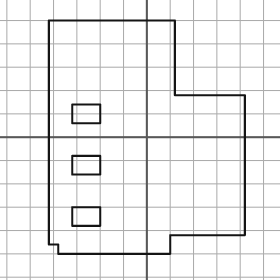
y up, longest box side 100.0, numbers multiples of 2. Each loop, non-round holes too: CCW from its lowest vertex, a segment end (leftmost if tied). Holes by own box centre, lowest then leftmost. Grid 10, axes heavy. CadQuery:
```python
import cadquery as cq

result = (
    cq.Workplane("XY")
    .moveTo(-38.0, -50.0)
    .lineTo(10.0, -50.0)
    .lineTo(10.0, -42.0)
    .lineTo(42.0, -42.0)
    .lineTo(42.0, 18.0)
    .lineTo(12.0, 18.0)
    .lineTo(12.0, 50.0)
    .lineTo(-42.0, 50.0)
    .lineTo(-42.0, -46.0)
    .lineTo(-38.0, -46.0)
    .close()
    .moveTo(-32.0, -38.0)
    .lineTo(-20.0, -38.0)
    .lineTo(-20.0, -30.0)
    .lineTo(-32.0, -30.0)
    .close()
    .moveTo(-32.0, -16.0)
    .lineTo(-20.0, -16.0)
    .lineTo(-20.0, -8.0)
    .lineTo(-32.0, -8.0)
    .close()
    .moveTo(-32.0, 6.0)
    .lineTo(-20.0, 6.0)
    .lineTo(-20.0, 14.0)
    .lineTo(-32.0, 14.0)
    .close()
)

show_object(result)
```